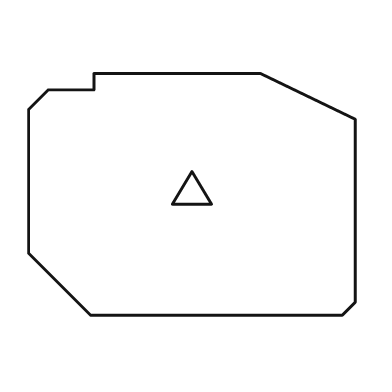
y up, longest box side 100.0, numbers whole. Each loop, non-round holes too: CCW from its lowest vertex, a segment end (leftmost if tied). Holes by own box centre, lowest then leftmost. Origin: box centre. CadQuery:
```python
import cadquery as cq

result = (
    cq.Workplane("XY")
    .moveTo(-31.0, -37.0)
    .lineTo(46.0, -37.0)
    .lineTo(50.0, -33.0)
    .lineTo(50.0, 23.0)
    .lineTo(21.0, 37.0)
    .lineTo(-30.0, 37.0)
    .lineTo(-30.0, 32.0)
    .lineTo(-44.0, 32.0)
    .lineTo(-50.0, 26.0)
    .lineTo(-50.0, -18.0)
    .close()
    .moveTo(-6.0, -3.0)
    .lineTo(6.0, -3.0)
    .lineTo(0.0, 7.0)
    .close()
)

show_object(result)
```